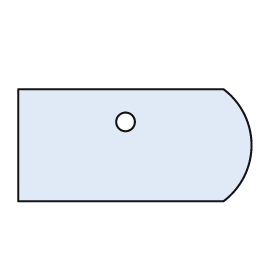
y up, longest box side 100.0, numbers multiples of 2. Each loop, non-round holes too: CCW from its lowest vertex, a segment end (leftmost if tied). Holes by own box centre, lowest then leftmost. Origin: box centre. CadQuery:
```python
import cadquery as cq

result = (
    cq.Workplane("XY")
    .moveTo(-50.0, -24.0)
    .lineTo(38.0, -24.0)
    .threePointArc((50.0, 0.0), (38.0, 24.0))
    .lineTo(-50.0, 24.0)
    .close()
    .moveTo(-4.0, 10.0)
    .circle(4.0)
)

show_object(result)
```